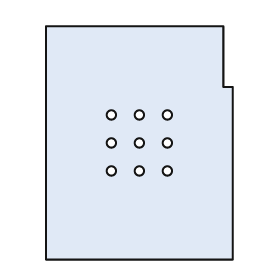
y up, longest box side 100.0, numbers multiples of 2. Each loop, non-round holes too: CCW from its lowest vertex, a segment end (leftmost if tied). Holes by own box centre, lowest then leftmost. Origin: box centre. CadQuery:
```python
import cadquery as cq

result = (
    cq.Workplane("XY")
    .moveTo(-40.0, -50.0)
    .lineTo(40.0, -50.0)
    .lineTo(40.0, 24.0)
    .lineTo(36.0, 24.0)
    .lineTo(36.0, 50.0)
    .lineTo(-40.0, 50.0)
    .close()
    .moveTo(-12.0, -12.0)
    .circle(2.0)
    .moveTo(0.0, -12.0)
    .circle(2.0)
    .moveTo(12.0, -12.0)
    .circle(2.0)
    .moveTo(-12.0, 0.0)
    .circle(2.0)
    .moveTo(0.0, 0.0)
    .circle(2.0)
    .moveTo(12.0, 0.0)
    .circle(2.0)
    .moveTo(-12.0, 12.0)
    .circle(2.0)
    .moveTo(0.0, 12.0)
    .circle(2.0)
    .moveTo(12.0, 12.0)
    .circle(2.0)
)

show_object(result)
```